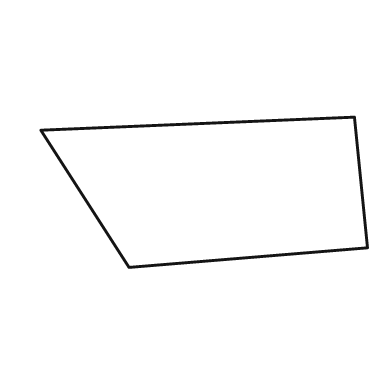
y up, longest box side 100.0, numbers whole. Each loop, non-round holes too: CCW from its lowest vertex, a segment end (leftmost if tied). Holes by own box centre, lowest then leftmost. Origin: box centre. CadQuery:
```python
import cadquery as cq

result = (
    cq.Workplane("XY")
    .moveTo(-23.0, -23.0)
    .lineTo(50.0, -17.0)
    .lineTo(46.0, 23.0)
    .lineTo(-50.0, 19.0)
    .close()
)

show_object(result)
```